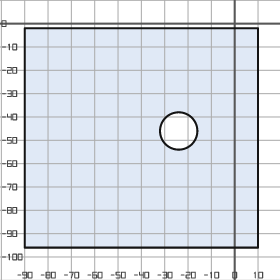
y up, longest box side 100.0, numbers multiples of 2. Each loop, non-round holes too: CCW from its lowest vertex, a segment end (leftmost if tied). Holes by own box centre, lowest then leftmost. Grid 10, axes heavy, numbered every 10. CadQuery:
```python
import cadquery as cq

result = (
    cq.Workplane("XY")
    .moveTo(-90.0, -96.0)
    .lineTo(10.0, -96.0)
    .lineTo(10.0, -2.0)
    .lineTo(-90.0, -2.0)
    .close()
    .moveTo(-24.0, -46.0)
    .circle(8.0)
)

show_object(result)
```